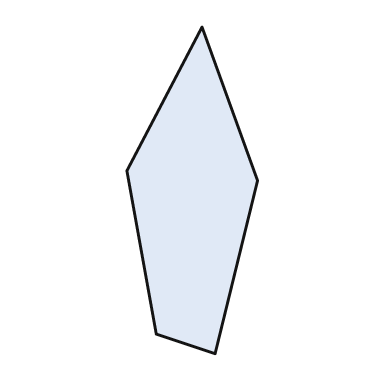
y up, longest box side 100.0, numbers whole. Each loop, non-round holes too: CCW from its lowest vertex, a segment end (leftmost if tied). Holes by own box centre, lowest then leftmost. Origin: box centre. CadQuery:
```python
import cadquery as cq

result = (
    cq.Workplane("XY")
    .moveTo(7.0, -50.0)
    .lineTo(20.0, 3.0)
    .lineTo(3.0, 50.0)
    .lineTo(-20.0, 6.0)
    .lineTo(-11.0, -44.0)
    .close()
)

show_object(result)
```